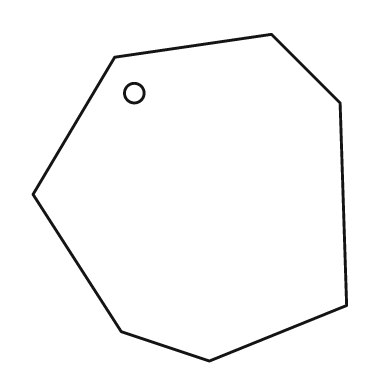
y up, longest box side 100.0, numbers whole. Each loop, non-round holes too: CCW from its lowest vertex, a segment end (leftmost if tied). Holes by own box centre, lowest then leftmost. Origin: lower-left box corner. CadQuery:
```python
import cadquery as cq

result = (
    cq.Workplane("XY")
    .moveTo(54.0, 0.0)
    .lineTo(96.0, 17.0)
    .lineTo(94.0, 79.0)
    .lineTo(73.0, 100.0)
    .lineTo(25.0, 93.0)
    .lineTo(0.0, 51.0)
    .lineTo(27.0, 9.0)
    .close()
    .moveTo(31.0, 82.0)
    .circle(3.0)
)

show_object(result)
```